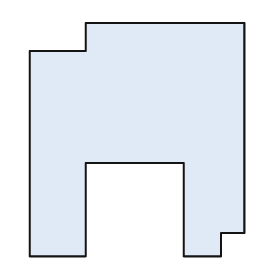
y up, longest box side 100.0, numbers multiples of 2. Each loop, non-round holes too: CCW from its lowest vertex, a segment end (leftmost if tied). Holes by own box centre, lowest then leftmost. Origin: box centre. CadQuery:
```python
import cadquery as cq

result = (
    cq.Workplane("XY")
    .moveTo(-46.0, -50.0)
    .lineTo(-22.0, -50.0)
    .lineTo(-22.0, -10.0)
    .lineTo(20.0, -10.0)
    .lineTo(20.0, -50.0)
    .lineTo(36.0, -50.0)
    .lineTo(36.0, -40.0)
    .lineTo(46.0, -40.0)
    .lineTo(46.0, 50.0)
    .lineTo(-22.0, 50.0)
    .lineTo(-22.0, 38.0)
    .lineTo(-46.0, 38.0)
    .close()
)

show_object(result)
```